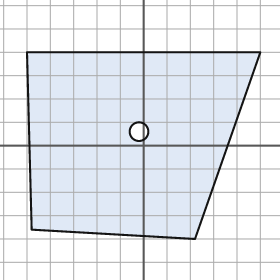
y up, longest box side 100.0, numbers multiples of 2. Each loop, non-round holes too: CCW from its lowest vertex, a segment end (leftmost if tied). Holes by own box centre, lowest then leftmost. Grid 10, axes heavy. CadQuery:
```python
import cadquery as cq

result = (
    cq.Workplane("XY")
    .moveTo(22.0, -40.0)
    .lineTo(50.0, 40.0)
    .lineTo(-50.0, 40.0)
    .lineTo(-48.0, -36.0)
    .close()
    .moveTo(-2.0, 6.0)
    .circle(4.0)
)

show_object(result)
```